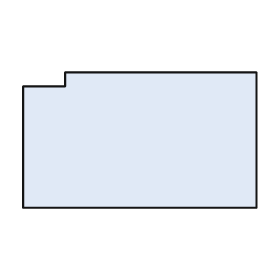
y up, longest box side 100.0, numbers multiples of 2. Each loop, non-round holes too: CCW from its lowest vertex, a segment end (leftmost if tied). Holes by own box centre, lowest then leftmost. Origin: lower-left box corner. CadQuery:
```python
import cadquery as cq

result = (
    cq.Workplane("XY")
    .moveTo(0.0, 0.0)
    .lineTo(100.0, 0.0)
    .lineTo(100.0, 58.0)
    .lineTo(18.0, 58.0)
    .lineTo(18.0, 52.0)
    .lineTo(0.0, 52.0)
    .close()
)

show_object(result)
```